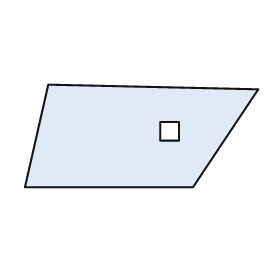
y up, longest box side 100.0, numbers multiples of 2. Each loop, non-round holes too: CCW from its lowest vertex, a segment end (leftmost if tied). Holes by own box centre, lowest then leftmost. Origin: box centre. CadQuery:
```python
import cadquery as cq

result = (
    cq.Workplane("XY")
    .moveTo(-50.0, -22.0)
    .lineTo(22.0, -22.0)
    .lineTo(50.0, 20.0)
    .lineTo(-40.0, 22.0)
    .close()
    .moveTo(8.0, -2.0)
    .lineTo(16.0, -2.0)
    .lineTo(16.0, 6.0)
    .lineTo(8.0, 6.0)
    .close()
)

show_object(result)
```